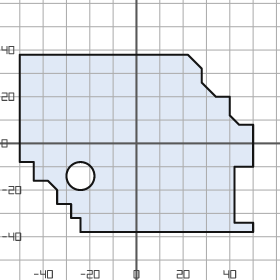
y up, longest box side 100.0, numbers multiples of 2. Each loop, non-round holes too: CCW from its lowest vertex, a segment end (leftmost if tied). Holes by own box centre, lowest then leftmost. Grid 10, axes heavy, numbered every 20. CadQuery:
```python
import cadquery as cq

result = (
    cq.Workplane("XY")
    .moveTo(-24.0, -38.0)
    .lineTo(50.0, -38.0)
    .lineTo(50.0, -34.0)
    .lineTo(42.0, -34.0)
    .lineTo(42.0, -10.0)
    .lineTo(50.0, -10.0)
    .lineTo(50.0, 8.0)
    .lineTo(44.0, 8.0)
    .lineTo(40.0, 12.0)
    .lineTo(40.0, 20.0)
    .lineTo(34.0, 20.0)
    .lineTo(28.0, 26.0)
    .lineTo(28.0, 32.0)
    .lineTo(22.0, 38.0)
    .lineTo(-50.0, 38.0)
    .lineTo(-50.0, -8.0)
    .lineTo(-44.0, -8.0)
    .lineTo(-44.0, -16.0)
    .lineTo(-38.0, -16.0)
    .lineTo(-34.0, -20.0)
    .lineTo(-34.0, -26.0)
    .lineTo(-28.0, -26.0)
    .lineTo(-28.0, -32.0)
    .lineTo(-24.0, -32.0)
    .close()
    .moveTo(-24.0, -14.0)
    .circle(6.0)
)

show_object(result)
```